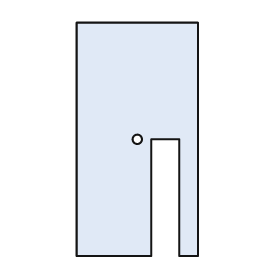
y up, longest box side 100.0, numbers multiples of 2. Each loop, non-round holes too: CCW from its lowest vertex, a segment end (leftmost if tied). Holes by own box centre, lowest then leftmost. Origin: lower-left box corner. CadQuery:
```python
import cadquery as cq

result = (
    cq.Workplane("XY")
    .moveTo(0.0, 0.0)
    .lineTo(32.0, 0.0)
    .lineTo(32.0, 50.0)
    .lineTo(44.0, 50.0)
    .lineTo(44.0, 0.0)
    .lineTo(52.0, 0.0)
    .lineTo(52.0, 100.0)
    .lineTo(0.0, 100.0)
    .close()
    .moveTo(26.0, 50.0)
    .circle(2.0)
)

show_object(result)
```